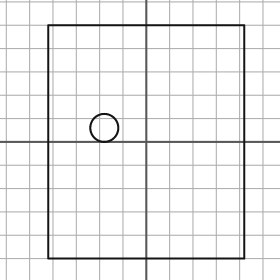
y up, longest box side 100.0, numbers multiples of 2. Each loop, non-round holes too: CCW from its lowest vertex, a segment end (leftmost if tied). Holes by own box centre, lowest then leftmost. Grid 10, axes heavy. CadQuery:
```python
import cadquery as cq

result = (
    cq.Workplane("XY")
    .moveTo(-42.0, -50.0)
    .lineTo(42.0, -50.0)
    .lineTo(42.0, 50.0)
    .lineTo(-42.0, 50.0)
    .close()
    .moveTo(-18.0, 6.0)
    .circle(6.0)
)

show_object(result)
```